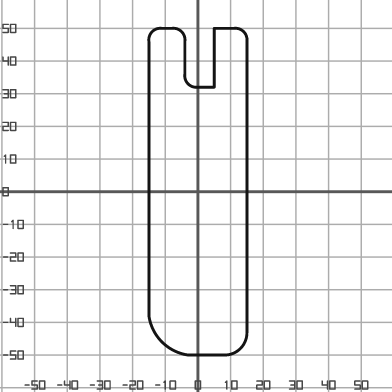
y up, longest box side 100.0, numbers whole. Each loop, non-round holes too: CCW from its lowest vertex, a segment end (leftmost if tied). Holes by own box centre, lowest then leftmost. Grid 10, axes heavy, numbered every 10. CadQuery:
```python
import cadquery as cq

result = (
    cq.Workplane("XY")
    .moveTo(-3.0, -50.0)
    .lineTo(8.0, -50.0)
    .threePointArc((13.0, -48.0), (15.0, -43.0))
    .lineTo(15.0, 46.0)
    .threePointArc((14.0, 49.0), (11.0, 50.0))
    .lineTo(5.0, 50.0)
    .lineTo(5.0, 32.0)
    .lineTo(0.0, 32.0)
    .threePointArc((-3.0, 33.0), (-4.0, 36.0))
    .lineTo(-4.0, 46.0)
    .threePointArc((-5.0, 49.0), (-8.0, 50.0))
    .lineTo(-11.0, 50.0)
    .threePointArc((-14.0, 49.0), (-15.0, 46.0))
    .lineTo(-15.0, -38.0)
    .threePointArc((-11.0, -46.0), (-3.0, -50.0))
    .close()
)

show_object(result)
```